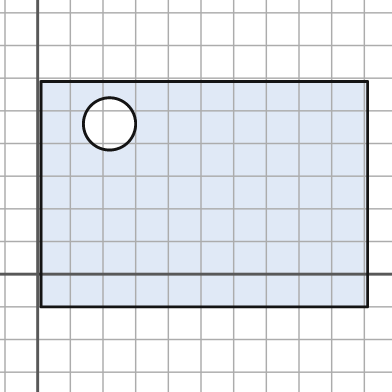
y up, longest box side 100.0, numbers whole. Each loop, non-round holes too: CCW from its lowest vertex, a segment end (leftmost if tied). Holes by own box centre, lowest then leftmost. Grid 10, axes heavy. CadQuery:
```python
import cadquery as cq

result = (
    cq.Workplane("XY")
    .moveTo(1.0, -10.0)
    .lineTo(101.0, -10.0)
    .lineTo(101.0, 59.0)
    .lineTo(1.0, 59.0)
    .close()
    .moveTo(22.0, 46.0)
    .circle(8.0)
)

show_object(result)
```